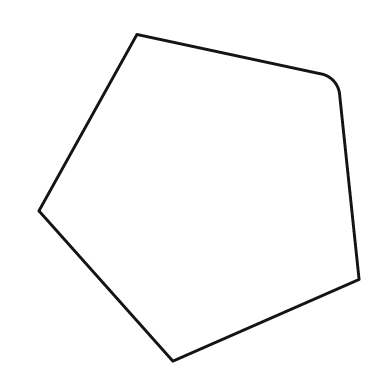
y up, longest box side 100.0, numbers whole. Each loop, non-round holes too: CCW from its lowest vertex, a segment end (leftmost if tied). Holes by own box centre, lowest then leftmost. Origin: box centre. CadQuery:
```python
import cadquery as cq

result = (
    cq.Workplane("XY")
    .moveTo(-8.0, -50.0)
    .lineTo(49.0, -25.0)
    .lineTo(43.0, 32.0)
    .threePointArc((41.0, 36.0), (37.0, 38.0))
    .lineTo(-19.0, 50.0)
    .lineTo(-49.0, -4.0)
    .close()
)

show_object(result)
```